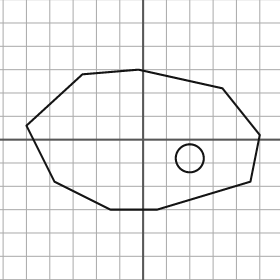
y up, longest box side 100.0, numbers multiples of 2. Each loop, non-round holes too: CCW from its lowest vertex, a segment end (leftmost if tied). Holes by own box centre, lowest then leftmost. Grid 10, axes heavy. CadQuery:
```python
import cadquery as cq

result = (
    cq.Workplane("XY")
    .moveTo(-14.0, -30.0)
    .lineTo(6.0, -30.0)
    .lineTo(46.0, -18.0)
    .lineTo(50.0, 2.0)
    .lineTo(34.0, 22.0)
    .lineTo(-2.0, 30.0)
    .lineTo(-26.0, 28.0)
    .lineTo(-50.0, 6.0)
    .lineTo(-38.0, -18.0)
    .close()
    .moveTo(20.0, -8.0)
    .circle(6.0)
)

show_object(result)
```